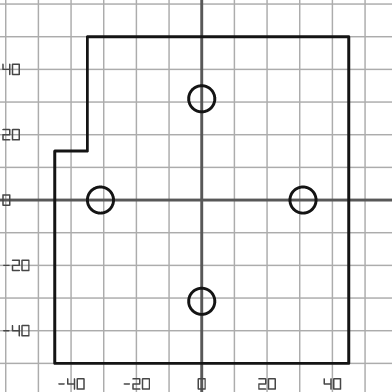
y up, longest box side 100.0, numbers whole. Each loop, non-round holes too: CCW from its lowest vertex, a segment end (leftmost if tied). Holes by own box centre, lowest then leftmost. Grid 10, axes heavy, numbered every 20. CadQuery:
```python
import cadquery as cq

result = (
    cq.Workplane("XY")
    .moveTo(-45.0, -50.0)
    .lineTo(45.0, -50.0)
    .lineTo(45.0, 50.0)
    .lineTo(-35.0, 50.0)
    .lineTo(-35.0, 15.0)
    .lineTo(-45.0, 15.0)
    .close()
    .moveTo(0.0, -31.0)
    .circle(4.0)
    .moveTo(-31.0, 0.0)
    .circle(4.0)
    .moveTo(31.0, 0.0)
    .circle(4.0)
    .moveTo(0.0, 31.0)
    .circle(4.0)
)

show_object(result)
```